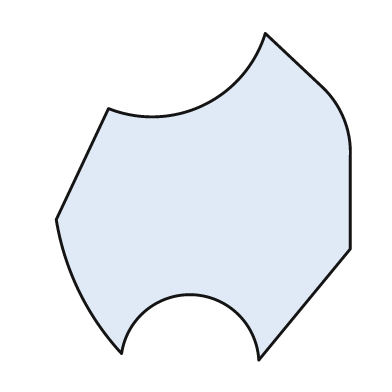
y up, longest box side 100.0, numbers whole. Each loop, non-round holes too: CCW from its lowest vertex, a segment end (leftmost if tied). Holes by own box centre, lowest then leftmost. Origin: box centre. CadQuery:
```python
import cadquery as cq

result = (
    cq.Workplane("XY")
    .moveTo(17.0, -50.0)
    .lineTo(45.0, -16.0)
    .lineTo(45.0, 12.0)
    .threePointArc((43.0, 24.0), (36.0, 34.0))
    .lineTo(19.0, 50.0)
    .threePointArc((0.0, 28.0), (-29.0, 27.0))
    .lineTo(-45.0, -7.0)
    .threePointArc((-38.0, -29.0), (-25.0, -48.0))
    .threePointArc((-3.0, -30.0), (17.0, -50.0))
    .close()
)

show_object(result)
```